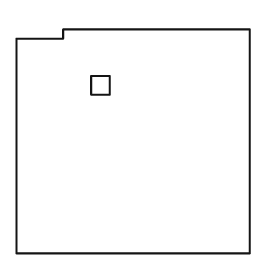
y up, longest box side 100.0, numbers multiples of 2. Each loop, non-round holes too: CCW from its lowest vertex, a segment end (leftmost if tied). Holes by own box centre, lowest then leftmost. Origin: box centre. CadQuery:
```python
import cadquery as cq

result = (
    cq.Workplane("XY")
    .moveTo(-50.0, -48.0)
    .lineTo(50.0, -48.0)
    .lineTo(50.0, 48.0)
    .lineTo(-30.0, 48.0)
    .lineTo(-30.0, 44.0)
    .lineTo(-50.0, 44.0)
    .close()
    .moveTo(-18.0, 20.0)
    .lineTo(-10.0, 20.0)
    .lineTo(-10.0, 28.0)
    .lineTo(-18.0, 28.0)
    .close()
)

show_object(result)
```